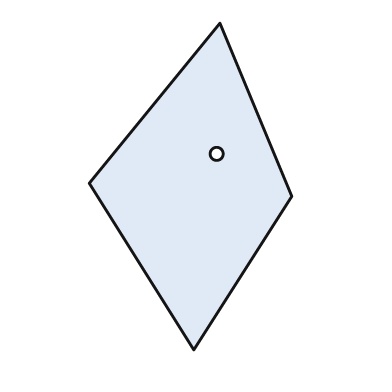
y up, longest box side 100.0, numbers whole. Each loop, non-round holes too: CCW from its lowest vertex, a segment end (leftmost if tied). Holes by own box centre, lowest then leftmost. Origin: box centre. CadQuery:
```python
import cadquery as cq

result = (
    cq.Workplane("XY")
    .moveTo(1.0, -50.0)
    .lineTo(31.0, -3.0)
    .lineTo(9.0, 50.0)
    .lineTo(-31.0, 1.0)
    .close()
    .moveTo(8.0, 10.0)
    .circle(2.0)
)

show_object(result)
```